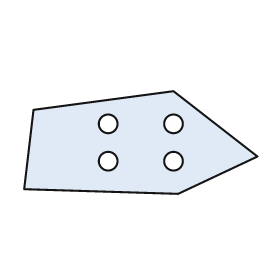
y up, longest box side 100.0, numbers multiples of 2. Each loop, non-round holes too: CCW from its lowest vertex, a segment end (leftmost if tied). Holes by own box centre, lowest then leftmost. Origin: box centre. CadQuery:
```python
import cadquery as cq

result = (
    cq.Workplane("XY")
    .moveTo(16.0, -22.0)
    .lineTo(50.0, -6.0)
    .lineTo(14.0, 22.0)
    .lineTo(-46.0, 14.0)
    .lineTo(-50.0, -20.0)
    .close()
    .moveTo(-14.0, -8.0)
    .circle(4.0)
    .moveTo(14.0, -8.0)
    .circle(4.0)
    .moveTo(-14.0, 8.0)
    .circle(4.0)
    .moveTo(14.0, 8.0)
    .circle(4.0)
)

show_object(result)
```